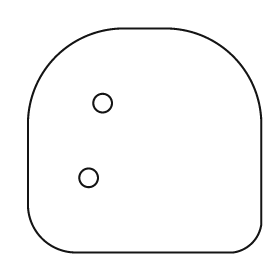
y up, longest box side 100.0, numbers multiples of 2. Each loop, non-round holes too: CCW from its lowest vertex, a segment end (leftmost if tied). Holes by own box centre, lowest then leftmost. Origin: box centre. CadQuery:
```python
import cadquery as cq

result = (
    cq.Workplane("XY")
    .moveTo(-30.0, -48.0)
    .lineTo(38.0, -48.0)
    .threePointArc((46.0, -44.0), (50.0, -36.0))
    .lineTo(50.0, 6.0)
    .threePointArc((38.0, 36.0), (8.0, 48.0))
    .lineTo(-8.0, 48.0)
    .threePointArc((-38.0, 36.0), (-50.0, 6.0))
    .lineTo(-50.0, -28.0)
    .threePointArc((-44.0, -42.0), (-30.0, -48.0))
    .close()
    .moveTo(-24.0, -16.0)
    .circle(4.0)
    .moveTo(-18.0, 16.0)
    .circle(4.0)
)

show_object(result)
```